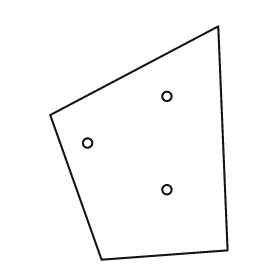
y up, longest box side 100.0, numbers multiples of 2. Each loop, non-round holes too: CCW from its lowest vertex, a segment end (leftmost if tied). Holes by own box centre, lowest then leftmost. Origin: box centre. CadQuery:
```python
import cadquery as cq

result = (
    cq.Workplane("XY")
    .moveTo(-16.0, -50.0)
    .lineTo(38.0, -46.0)
    .lineTo(34.0, 50.0)
    .lineTo(-38.0, 12.0)
    .close()
    .moveTo(12.0, -20.0)
    .circle(2.0)
    .moveTo(-22.0, 0.0)
    .circle(2.0)
    .moveTo(12.0, 20.0)
    .circle(2.0)
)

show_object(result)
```